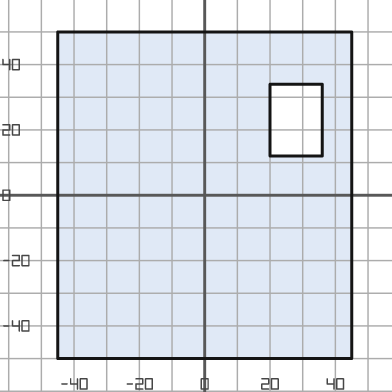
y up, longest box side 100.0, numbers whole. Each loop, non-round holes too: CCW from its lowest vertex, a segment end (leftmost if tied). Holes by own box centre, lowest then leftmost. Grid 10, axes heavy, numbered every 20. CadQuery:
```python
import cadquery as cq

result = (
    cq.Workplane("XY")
    .moveTo(-45.0, -50.0)
    .lineTo(45.0, -50.0)
    .lineTo(45.0, 50.0)
    .lineTo(-45.0, 50.0)
    .close()
    .moveTo(20.0, 12.0)
    .lineTo(36.0, 12.0)
    .lineTo(36.0, 34.0)
    .lineTo(20.0, 34.0)
    .close()
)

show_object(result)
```